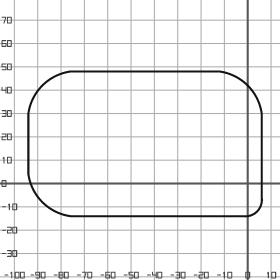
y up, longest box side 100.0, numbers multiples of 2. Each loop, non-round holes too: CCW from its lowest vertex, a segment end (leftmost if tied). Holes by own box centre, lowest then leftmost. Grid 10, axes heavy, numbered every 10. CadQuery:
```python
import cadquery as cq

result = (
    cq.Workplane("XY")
    .moveTo(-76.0, -14.0)
    .lineTo(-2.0, -14.0)
    .threePointArc((4.0, -12.0), (6.0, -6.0))
    .lineTo(6.0, 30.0)
    .threePointArc((0.0, 42.0), (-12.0, 48.0))
    .lineTo(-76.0, 48.0)
    .threePointArc((-88.0, 42.0), (-94.0, 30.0))
    .lineTo(-94.0, 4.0)
    .threePointArc((-88.0, -8.0), (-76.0, -14.0))
    .close()
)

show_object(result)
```